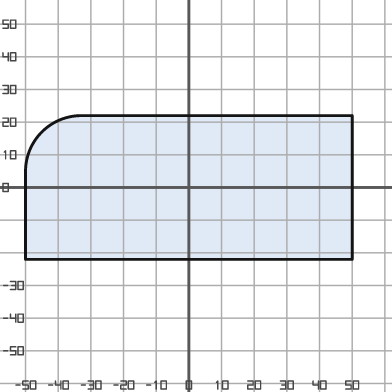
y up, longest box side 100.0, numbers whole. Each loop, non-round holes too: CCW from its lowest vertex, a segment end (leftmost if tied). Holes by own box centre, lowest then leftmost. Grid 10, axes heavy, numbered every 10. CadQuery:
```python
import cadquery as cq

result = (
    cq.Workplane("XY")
    .moveTo(-50.0, -22.0)
    .lineTo(50.0, -22.0)
    .lineTo(50.0, 22.0)
    .lineTo(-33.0, 22.0)
    .threePointArc((-45.0, 17.0), (-50.0, 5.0))
    .close()
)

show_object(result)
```